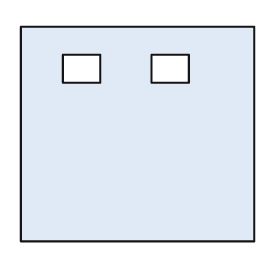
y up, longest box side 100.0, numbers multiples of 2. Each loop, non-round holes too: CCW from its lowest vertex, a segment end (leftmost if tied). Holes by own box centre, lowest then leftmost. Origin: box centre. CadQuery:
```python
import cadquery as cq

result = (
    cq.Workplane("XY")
    .moveTo(-50.0, -46.0)
    .lineTo(50.0, -46.0)
    .lineTo(50.0, 46.0)
    .lineTo(-50.0, 46.0)
    .close()
    .moveTo(-32.0, 22.0)
    .lineTo(-16.0, 22.0)
    .lineTo(-16.0, 34.0)
    .lineTo(-32.0, 34.0)
    .close()
    .moveTo(6.0, 22.0)
    .lineTo(22.0, 22.0)
    .lineTo(22.0, 34.0)
    .lineTo(6.0, 34.0)
    .close()
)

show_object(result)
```